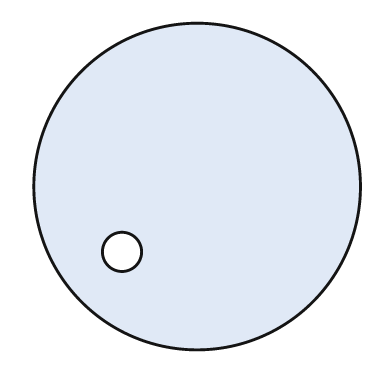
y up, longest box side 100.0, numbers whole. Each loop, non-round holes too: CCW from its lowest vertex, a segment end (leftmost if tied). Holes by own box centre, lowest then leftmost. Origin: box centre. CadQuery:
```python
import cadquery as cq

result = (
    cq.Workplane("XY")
    .moveTo(0.0, 0.0)
    .circle(50.0)
    .moveTo(-23.0, -20.0)
    .circle(6.0)
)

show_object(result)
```